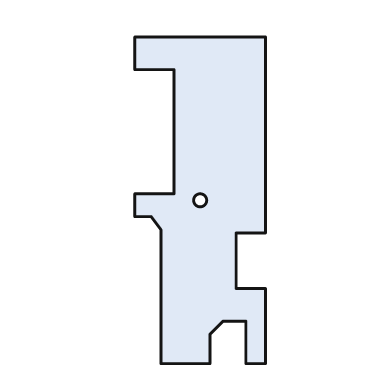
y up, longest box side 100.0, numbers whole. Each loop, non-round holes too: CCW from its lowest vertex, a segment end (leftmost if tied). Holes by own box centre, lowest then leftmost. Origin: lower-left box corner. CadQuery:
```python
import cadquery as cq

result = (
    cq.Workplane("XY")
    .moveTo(8.0, 0.0)
    .lineTo(23.0, 0.0)
    .lineTo(23.0, 9.0)
    .lineTo(27.0, 13.0)
    .lineTo(34.0, 13.0)
    .lineTo(34.0, 0.0)
    .lineTo(40.0, 0.0)
    .lineTo(40.0, 23.0)
    .lineTo(31.0, 23.0)
    .lineTo(31.0, 40.0)
    .lineTo(40.0, 40.0)
    .lineTo(40.0, 100.0)
    .lineTo(0.0, 100.0)
    .lineTo(0.0, 90.0)
    .lineTo(12.0, 90.0)
    .lineTo(12.0, 52.0)
    .lineTo(0.0, 52.0)
    .lineTo(0.0, 45.0)
    .lineTo(5.0, 45.0)
    .lineTo(8.0, 41.0)
    .close()
    .moveTo(20.0, 50.0)
    .circle(2.0)
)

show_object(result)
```